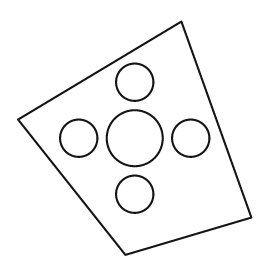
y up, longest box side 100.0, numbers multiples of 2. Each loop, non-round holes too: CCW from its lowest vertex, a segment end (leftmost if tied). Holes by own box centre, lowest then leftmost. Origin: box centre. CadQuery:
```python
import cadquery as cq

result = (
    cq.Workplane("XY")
    .moveTo(-4.0, -50.0)
    .lineTo(50.0, -34.0)
    .lineTo(20.0, 50.0)
    .lineTo(-50.0, 8.0)
    .close()
    .moveTo(0.0, -24.0)
    .circle(8.0)
    .moveTo(-24.0, 0.0)
    .circle(8.0)
    .moveTo(0.0, 0.0)
    .circle(12.0)
    .moveTo(24.0, 0.0)
    .circle(8.0)
    .moveTo(0.0, 24.0)
    .circle(8.0)
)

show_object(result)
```